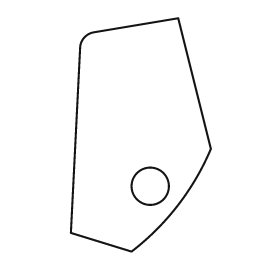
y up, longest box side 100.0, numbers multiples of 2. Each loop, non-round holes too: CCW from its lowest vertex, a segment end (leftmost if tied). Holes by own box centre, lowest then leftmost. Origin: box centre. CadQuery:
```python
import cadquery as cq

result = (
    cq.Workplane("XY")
    .moveTo(-4.0, -50.0)
    .threePointArc((16.0, -30.0), (30.0, -6.0))
    .lineTo(16.0, 50.0)
    .lineTo(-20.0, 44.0)
    .threePointArc((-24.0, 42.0), (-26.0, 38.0))
    .lineTo(-30.0, -42.0)
    .close()
    .moveTo(4.0, -22.0)
    .circle(8.0)
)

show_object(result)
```